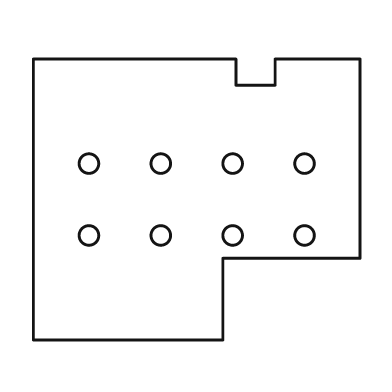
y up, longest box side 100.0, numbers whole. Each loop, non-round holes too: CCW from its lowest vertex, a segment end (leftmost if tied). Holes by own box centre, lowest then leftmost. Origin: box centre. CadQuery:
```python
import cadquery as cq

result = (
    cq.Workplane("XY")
    .moveTo(-50.0, -43.0)
    .lineTo(8.0, -43.0)
    .lineTo(8.0, -18.0)
    .lineTo(50.0, -18.0)
    .lineTo(50.0, 43.0)
    .lineTo(24.0, 43.0)
    .lineTo(24.0, 35.0)
    .lineTo(12.0, 35.0)
    .lineTo(12.0, 43.0)
    .lineTo(-50.0, 43.0)
    .close()
    .moveTo(-33.0, -11.0)
    .circle(3.0)
    .moveTo(-11.0, -11.0)
    .circle(3.0)
    .moveTo(11.0, -11.0)
    .circle(3.0)
    .moveTo(33.0, -11.0)
    .circle(3.0)
    .moveTo(-33.0, 11.0)
    .circle(3.0)
    .moveTo(-11.0, 11.0)
    .circle(3.0)
    .moveTo(11.0, 11.0)
    .circle(3.0)
    .moveTo(33.0, 11.0)
    .circle(3.0)
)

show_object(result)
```